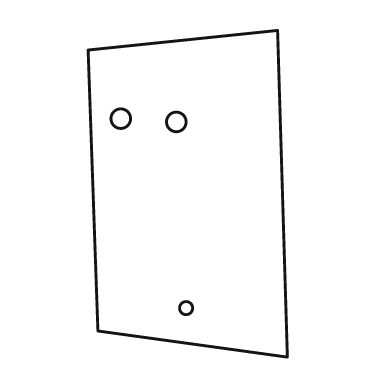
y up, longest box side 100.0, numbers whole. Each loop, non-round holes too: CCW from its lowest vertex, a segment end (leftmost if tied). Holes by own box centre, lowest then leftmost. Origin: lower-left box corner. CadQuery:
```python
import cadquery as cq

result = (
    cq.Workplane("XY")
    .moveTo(61.0, 0.0)
    .lineTo(58.0, 100.0)
    .lineTo(0.0, 94.0)
    .lineTo(3.0, 8.0)
    .close()
    .moveTo(30.0, 15.0)
    .circle(2.0)
    .moveTo(27.0, 72.0)
    .circle(3.0)
    .moveTo(10.0, 73.0)
    .circle(3.0)
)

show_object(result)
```